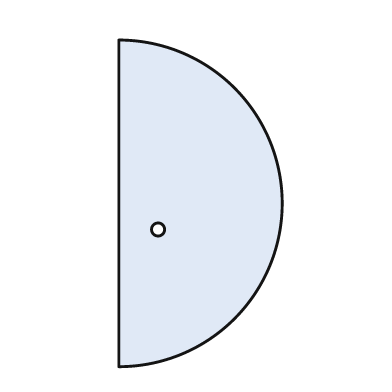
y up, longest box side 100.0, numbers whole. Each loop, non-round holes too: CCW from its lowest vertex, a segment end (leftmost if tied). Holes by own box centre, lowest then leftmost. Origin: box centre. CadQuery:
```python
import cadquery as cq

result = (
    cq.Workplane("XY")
    .moveTo(-25.0, -50.0)
    .threePointArc((25.0, 0.0), (-25.0, 50.0))
    .close()
    .moveTo(-13.0, -8.0)
    .circle(2.0)
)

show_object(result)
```